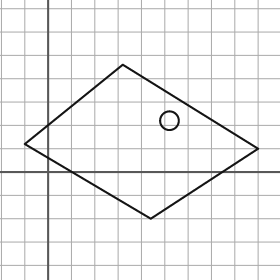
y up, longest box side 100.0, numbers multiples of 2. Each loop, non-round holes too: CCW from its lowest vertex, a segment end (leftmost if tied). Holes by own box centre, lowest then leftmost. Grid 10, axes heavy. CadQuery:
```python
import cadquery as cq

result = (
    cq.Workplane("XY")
    .moveTo(44.0, -20.0)
    .lineTo(90.0, 10.0)
    .lineTo(32.0, 46.0)
    .lineTo(-10.0, 12.0)
    .close()
    .moveTo(52.0, 22.0)
    .circle(4.0)
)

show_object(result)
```